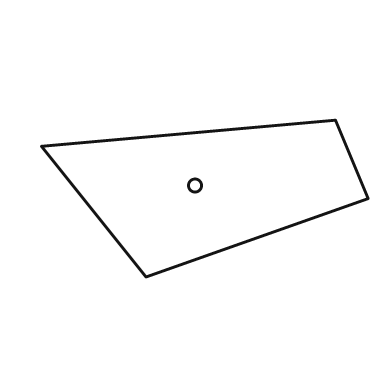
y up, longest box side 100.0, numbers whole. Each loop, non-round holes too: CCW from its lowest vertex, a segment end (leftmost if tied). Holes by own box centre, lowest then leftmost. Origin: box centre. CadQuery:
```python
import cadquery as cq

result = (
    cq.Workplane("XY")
    .moveTo(-18.0, -24.0)
    .lineTo(50.0, 0.0)
    .lineTo(40.0, 24.0)
    .lineTo(-50.0, 16.0)
    .close()
    .moveTo(-3.0, 4.0)
    .circle(2.0)
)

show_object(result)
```